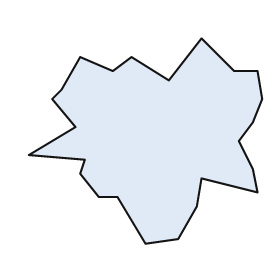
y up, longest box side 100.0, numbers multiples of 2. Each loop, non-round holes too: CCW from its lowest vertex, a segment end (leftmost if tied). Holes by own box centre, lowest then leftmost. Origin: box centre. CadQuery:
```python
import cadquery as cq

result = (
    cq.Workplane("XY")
    .moveTo(0.0, -44.0)
    .lineTo(14.0, -42.0)
    .lineTo(22.0, -28.0)
    .lineTo(24.0, -16.0)
    .lineTo(48.0, -22.0)
    .lineTo(46.0, -12.0)
    .lineTo(40.0, 0.0)
    .lineTo(46.0, 8.0)
    .lineTo(50.0, 18.0)
    .lineTo(48.0, 30.0)
    .lineTo(38.0, 30.0)
    .lineTo(24.0, 44.0)
    .lineTo(10.0, 26.0)
    .lineTo(-6.0, 36.0)
    .lineTo(-14.0, 30.0)
    .lineTo(-28.0, 36.0)
    .lineTo(-36.0, 22.0)
    .lineTo(-40.0, 18.0)
    .lineTo(-30.0, 6.0)
    .lineTo(-50.0, -6.0)
    .lineTo(-26.0, -8.0)
    .lineTo(-28.0, -14.0)
    .lineTo(-20.0, -24.0)
    .lineTo(-12.0, -24.0)
    .close()
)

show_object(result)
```